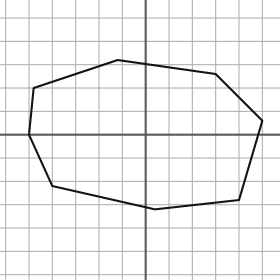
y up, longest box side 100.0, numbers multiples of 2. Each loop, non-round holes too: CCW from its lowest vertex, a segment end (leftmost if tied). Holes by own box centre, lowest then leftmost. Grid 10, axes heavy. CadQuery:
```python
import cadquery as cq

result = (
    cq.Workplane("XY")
    .moveTo(4.0, -32.0)
    .lineTo(40.0, -28.0)
    .lineTo(50.0, 6.0)
    .lineTo(30.0, 26.0)
    .lineTo(-12.0, 32.0)
    .lineTo(-48.0, 20.0)
    .lineTo(-50.0, 0.0)
    .lineTo(-40.0, -22.0)
    .close()
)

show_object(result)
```